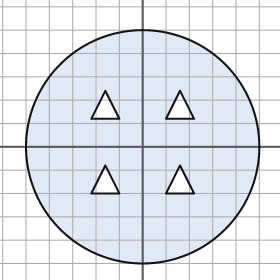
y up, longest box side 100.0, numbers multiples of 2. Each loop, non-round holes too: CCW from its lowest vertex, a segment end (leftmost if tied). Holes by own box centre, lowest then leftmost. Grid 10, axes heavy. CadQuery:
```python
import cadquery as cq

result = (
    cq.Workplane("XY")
    .moveTo(0.0, 0.0)
    .circle(50.0)
    .moveTo(-22.0, -20.0)
    .lineTo(-10.0, -20.0)
    .lineTo(-16.0, -8.0)
    .close()
    .moveTo(10.0, -20.0)
    .lineTo(22.0, -20.0)
    .lineTo(16.0, -8.0)
    .close()
    .moveTo(-22.0, 12.0)
    .lineTo(-10.0, 12.0)
    .lineTo(-16.0, 24.0)
    .close()
    .moveTo(10.0, 12.0)
    .lineTo(22.0, 12.0)
    .lineTo(16.0, 24.0)
    .close()
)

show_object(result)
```